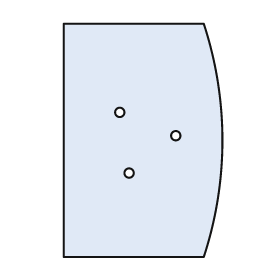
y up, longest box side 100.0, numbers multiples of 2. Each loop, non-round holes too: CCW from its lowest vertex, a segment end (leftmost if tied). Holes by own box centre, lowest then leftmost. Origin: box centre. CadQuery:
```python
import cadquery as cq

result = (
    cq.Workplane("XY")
    .moveTo(-34.0, -50.0)
    .lineTo(26.0, -50.0)
    .threePointArc((34.0, 0.0), (26.0, 50.0))
    .lineTo(-34.0, 50.0)
    .close()
    .moveTo(-6.0, -14.0)
    .circle(2.0)
    .moveTo(14.0, 2.0)
    .circle(2.0)
    .moveTo(-10.0, 12.0)
    .circle(2.0)
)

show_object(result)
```